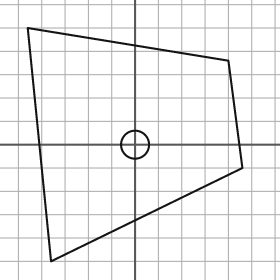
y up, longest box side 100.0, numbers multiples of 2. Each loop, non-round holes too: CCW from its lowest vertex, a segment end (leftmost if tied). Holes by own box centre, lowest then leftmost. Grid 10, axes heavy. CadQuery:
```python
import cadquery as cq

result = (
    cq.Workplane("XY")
    .moveTo(-36.0, -50.0)
    .lineTo(46.0, -10.0)
    .lineTo(40.0, 36.0)
    .lineTo(-46.0, 50.0)
    .close()
    .moveTo(0.0, 0.0)
    .circle(6.0)
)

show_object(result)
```